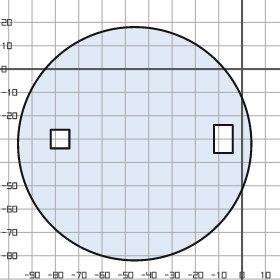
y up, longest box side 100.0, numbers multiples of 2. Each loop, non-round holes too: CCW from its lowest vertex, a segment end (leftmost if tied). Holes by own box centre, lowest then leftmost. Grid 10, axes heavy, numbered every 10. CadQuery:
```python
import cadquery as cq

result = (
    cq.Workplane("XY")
    .moveTo(-46.0, -32.0)
    .circle(50.0)
    .moveTo(-82.0, -34.0)
    .lineTo(-74.0, -34.0)
    .lineTo(-74.0, -26.0)
    .lineTo(-82.0, -26.0)
    .close()
    .moveTo(-12.0, -36.0)
    .lineTo(-4.0, -36.0)
    .lineTo(-4.0, -24.0)
    .lineTo(-12.0, -24.0)
    .close()
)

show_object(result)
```